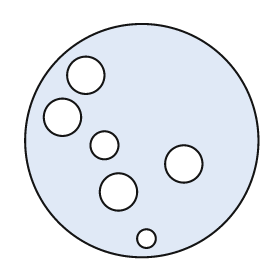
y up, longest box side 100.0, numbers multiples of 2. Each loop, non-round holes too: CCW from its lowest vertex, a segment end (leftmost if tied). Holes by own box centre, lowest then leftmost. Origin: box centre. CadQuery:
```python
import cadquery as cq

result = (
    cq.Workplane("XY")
    .moveTo(0.0, 0.0)
    .circle(50.0)
    .moveTo(2.0, -42.0)
    .circle(4.0)
    .moveTo(-10.0, -22.0)
    .circle(8.0)
    .moveTo(18.0, -10.0)
    .circle(8.0)
    .moveTo(-16.0, -2.0)
    .circle(6.0)
    .moveTo(-34.0, 10.0)
    .circle(8.0)
    .moveTo(-24.0, 28.0)
    .circle(8.0)
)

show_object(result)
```